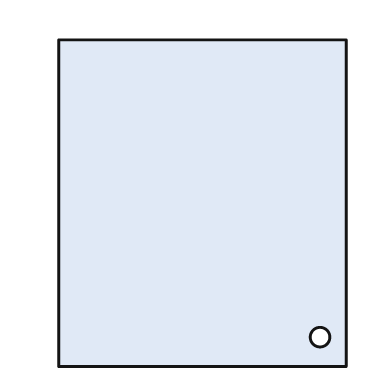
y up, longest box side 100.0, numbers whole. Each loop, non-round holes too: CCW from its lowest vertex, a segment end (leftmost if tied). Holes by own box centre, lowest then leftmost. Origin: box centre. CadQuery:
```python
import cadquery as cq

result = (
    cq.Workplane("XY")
    .moveTo(-44.0, -50.0)
    .lineTo(44.0, -50.0)
    .lineTo(44.0, 50.0)
    .lineTo(-44.0, 50.0)
    .close()
    .moveTo(36.0, -41.0)
    .circle(3.0)
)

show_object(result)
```